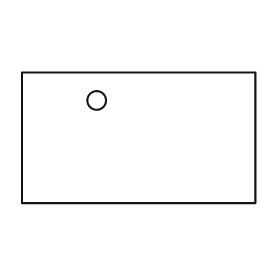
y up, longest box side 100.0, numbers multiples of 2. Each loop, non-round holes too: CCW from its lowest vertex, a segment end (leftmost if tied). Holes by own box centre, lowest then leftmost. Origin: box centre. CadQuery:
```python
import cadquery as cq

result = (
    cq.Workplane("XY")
    .moveTo(-50.0, -28.0)
    .lineTo(50.0, -28.0)
    .lineTo(50.0, 28.0)
    .lineTo(-50.0, 28.0)
    .close()
    .moveTo(-18.0, 16.0)
    .circle(4.0)
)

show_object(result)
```